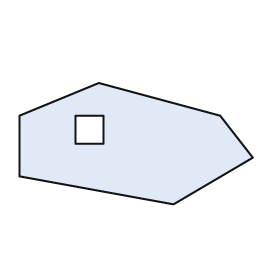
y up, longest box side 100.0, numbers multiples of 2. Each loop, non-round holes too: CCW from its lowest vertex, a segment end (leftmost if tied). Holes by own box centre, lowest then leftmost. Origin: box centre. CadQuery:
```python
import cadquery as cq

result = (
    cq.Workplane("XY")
    .moveTo(16.0, -26.0)
    .lineTo(50.0, -6.0)
    .lineTo(36.0, 12.0)
    .lineTo(-16.0, 26.0)
    .lineTo(-50.0, 12.0)
    .lineTo(-50.0, -14.0)
    .close()
    .moveTo(-26.0, 0.0)
    .lineTo(-14.0, 0.0)
    .lineTo(-14.0, 12.0)
    .lineTo(-26.0, 12.0)
    .close()
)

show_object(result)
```